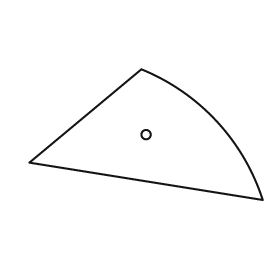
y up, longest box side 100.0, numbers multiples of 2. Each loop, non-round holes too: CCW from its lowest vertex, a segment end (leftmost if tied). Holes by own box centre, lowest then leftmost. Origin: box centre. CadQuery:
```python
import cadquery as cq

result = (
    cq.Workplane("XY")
    .moveTo(50.0, -28.0)
    .threePointArc((30.0, 6.0), (-2.0, 28.0))
    .lineTo(-50.0, -12.0)
    .close()
    .moveTo(0.0, 0.0)
    .circle(2.0)
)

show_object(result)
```